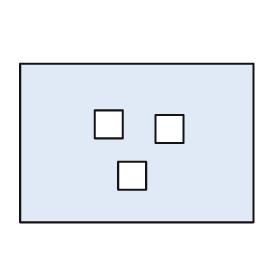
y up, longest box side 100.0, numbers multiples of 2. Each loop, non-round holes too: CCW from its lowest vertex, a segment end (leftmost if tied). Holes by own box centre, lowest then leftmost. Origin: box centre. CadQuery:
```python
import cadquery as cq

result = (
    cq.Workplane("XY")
    .moveTo(-50.0, -34.0)
    .lineTo(50.0, -34.0)
    .lineTo(50.0, 34.0)
    .lineTo(-50.0, 34.0)
    .close()
    .moveTo(-8.0, -20.0)
    .lineTo(4.0, -20.0)
    .lineTo(4.0, -8.0)
    .lineTo(-8.0, -8.0)
    .close()
    .moveTo(8.0, 0.0)
    .lineTo(20.0, 0.0)
    .lineTo(20.0, 12.0)
    .lineTo(8.0, 12.0)
    .close()
    .moveTo(-18.0, 2.0)
    .lineTo(-6.0, 2.0)
    .lineTo(-6.0, 14.0)
    .lineTo(-18.0, 14.0)
    .close()
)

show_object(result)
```